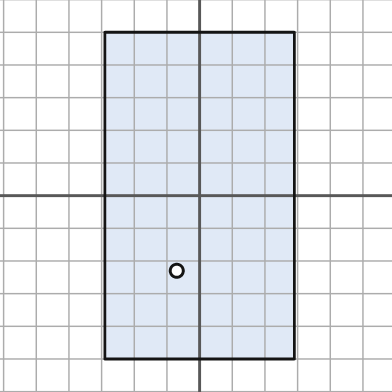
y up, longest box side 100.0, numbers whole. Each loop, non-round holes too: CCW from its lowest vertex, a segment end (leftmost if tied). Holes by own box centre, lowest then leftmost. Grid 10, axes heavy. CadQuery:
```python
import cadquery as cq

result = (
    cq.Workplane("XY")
    .moveTo(-29.0, -50.0)
    .lineTo(29.0, -50.0)
    .lineTo(29.0, 50.0)
    .lineTo(-29.0, 50.0)
    .close()
    .moveTo(-7.0, -23.0)
    .circle(2.0)
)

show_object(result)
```